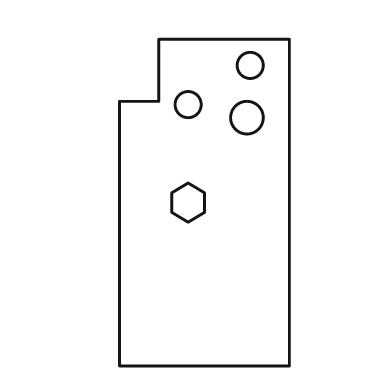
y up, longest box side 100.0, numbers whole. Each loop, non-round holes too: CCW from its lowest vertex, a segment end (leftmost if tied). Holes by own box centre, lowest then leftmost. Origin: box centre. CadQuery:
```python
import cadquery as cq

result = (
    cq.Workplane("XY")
    .moveTo(-26.0, -50.0)
    .lineTo(26.0, -50.0)
    .lineTo(26.0, 50.0)
    .lineTo(-14.0, 50.0)
    .lineTo(-14.0, 31.0)
    .lineTo(-26.0, 31.0)
    .close()
    .moveTo(-5.0, -6.0)
    .lineTo(0.0, -3.0)
    .lineTo(0.0, 3.0)
    .lineTo(-5.0, 6.0)
    .lineTo(-10.0, 3.0)
    .lineTo(-10.0, -3.0)
    .close()
    .moveTo(13.0, 26.0)
    .circle(5.0)
    .moveTo(-5.0, 30.0)
    .circle(4.0)
    .moveTo(14.0, 42.0)
    .circle(4.0)
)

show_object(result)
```